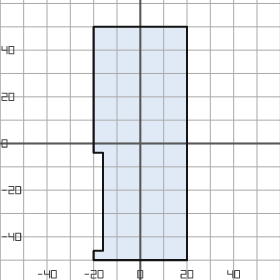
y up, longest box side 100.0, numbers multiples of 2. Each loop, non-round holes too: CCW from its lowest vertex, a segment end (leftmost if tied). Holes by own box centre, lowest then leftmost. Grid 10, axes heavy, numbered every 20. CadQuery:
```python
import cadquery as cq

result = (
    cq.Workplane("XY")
    .moveTo(-20.0, -50.0)
    .lineTo(20.0, -50.0)
    .lineTo(20.0, 50.0)
    .lineTo(-20.0, 50.0)
    .lineTo(-20.0, -4.0)
    .lineTo(-16.0, -4.0)
    .lineTo(-16.0, -46.0)
    .lineTo(-20.0, -46.0)
    .close()
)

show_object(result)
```